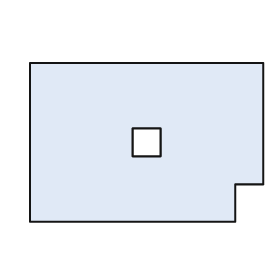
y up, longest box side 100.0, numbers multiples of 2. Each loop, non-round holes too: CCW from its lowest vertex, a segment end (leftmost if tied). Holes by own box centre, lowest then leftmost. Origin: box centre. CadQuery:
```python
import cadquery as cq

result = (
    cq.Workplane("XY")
    .moveTo(-50.0, -34.0)
    .lineTo(38.0, -34.0)
    .lineTo(38.0, -18.0)
    .lineTo(50.0, -18.0)
    .lineTo(50.0, 34.0)
    .lineTo(-50.0, 34.0)
    .close()
    .moveTo(-6.0, -6.0)
    .lineTo(6.0, -6.0)
    .lineTo(6.0, 6.0)
    .lineTo(-6.0, 6.0)
    .close()
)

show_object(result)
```